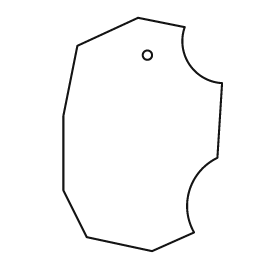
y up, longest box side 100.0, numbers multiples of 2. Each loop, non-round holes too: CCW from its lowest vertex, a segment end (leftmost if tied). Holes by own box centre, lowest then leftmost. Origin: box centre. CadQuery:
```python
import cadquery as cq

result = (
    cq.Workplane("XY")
    .moveTo(4.0, -50.0)
    .lineTo(22.0, -42.0)
    .threePointArc((20.0, -24.0), (32.0, -10.0))
    .lineTo(34.0, 22.0)
    .threePointArc((20.0, 30.0), (18.0, 46.0))
    .lineTo(-2.0, 50.0)
    .lineTo(-28.0, 38.0)
    .lineTo(-34.0, 8.0)
    .lineTo(-34.0, -24.0)
    .lineTo(-24.0, -44.0)
    .close()
    .moveTo(2.0, 34.0)
    .circle(2.0)
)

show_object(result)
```